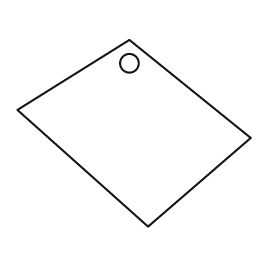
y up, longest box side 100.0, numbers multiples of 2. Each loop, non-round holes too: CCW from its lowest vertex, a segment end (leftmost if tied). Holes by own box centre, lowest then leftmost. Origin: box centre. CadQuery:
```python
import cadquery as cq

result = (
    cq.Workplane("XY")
    .moveTo(6.0, -40.0)
    .lineTo(50.0, -2.0)
    .lineTo(-2.0, 40.0)
    .lineTo(-50.0, 10.0)
    .close()
    .moveTo(-2.0, 30.0)
    .circle(4.0)
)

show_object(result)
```